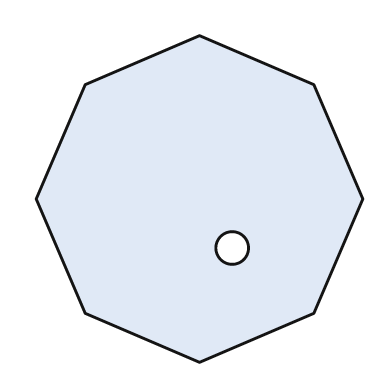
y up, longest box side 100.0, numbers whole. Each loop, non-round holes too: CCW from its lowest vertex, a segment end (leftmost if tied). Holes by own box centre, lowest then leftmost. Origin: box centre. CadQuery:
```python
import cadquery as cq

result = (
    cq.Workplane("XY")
    .moveTo(0.0, -50.0)
    .lineTo(35.0, -35.0)
    .lineTo(50.0, 0.0)
    .lineTo(35.0, 35.0)
    .lineTo(0.0, 50.0)
    .lineTo(-35.0, 35.0)
    .lineTo(-50.0, 0.0)
    .lineTo(-35.0, -35.0)
    .close()
    .moveTo(10.0, -15.0)
    .circle(5.0)
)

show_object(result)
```